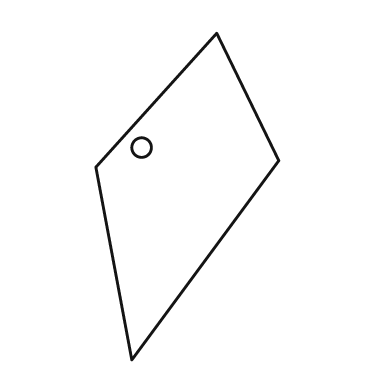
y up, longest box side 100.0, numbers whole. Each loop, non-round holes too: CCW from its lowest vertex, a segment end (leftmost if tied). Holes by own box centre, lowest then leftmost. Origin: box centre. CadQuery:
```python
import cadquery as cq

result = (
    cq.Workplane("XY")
    .moveTo(-17.0, -50.0)
    .lineTo(28.0, 11.0)
    .lineTo(9.0, 50.0)
    .lineTo(-28.0, 9.0)
    .close()
    .moveTo(-14.0, 15.0)
    .circle(3.0)
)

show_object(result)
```